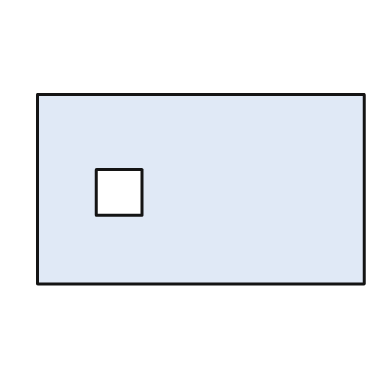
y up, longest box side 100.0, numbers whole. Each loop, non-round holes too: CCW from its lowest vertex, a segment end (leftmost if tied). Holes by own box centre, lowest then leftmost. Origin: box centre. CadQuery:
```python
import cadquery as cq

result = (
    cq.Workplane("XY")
    .moveTo(-50.0, -29.0)
    .lineTo(50.0, -29.0)
    .lineTo(50.0, 29.0)
    .lineTo(-50.0, 29.0)
    .close()
    .moveTo(-32.0, -8.0)
    .lineTo(-18.0, -8.0)
    .lineTo(-18.0, 6.0)
    .lineTo(-32.0, 6.0)
    .close()
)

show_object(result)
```